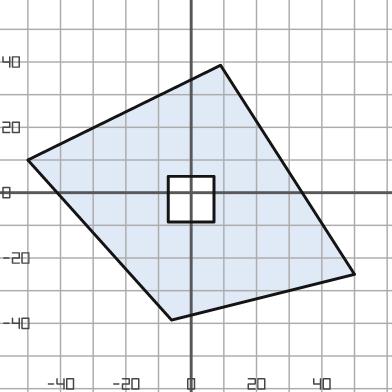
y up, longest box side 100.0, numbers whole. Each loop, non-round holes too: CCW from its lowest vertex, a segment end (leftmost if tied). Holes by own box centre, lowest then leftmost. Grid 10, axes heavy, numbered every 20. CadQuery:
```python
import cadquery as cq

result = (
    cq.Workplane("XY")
    .moveTo(-6.0, -39.0)
    .lineTo(50.0, -25.0)
    .lineTo(9.0, 39.0)
    .lineTo(-50.0, 10.0)
    .close()
    .moveTo(-7.0, -9.0)
    .lineTo(7.0, -9.0)
    .lineTo(7.0, 5.0)
    .lineTo(-7.0, 5.0)
    .close()
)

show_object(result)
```